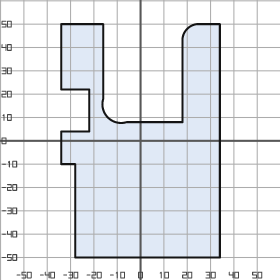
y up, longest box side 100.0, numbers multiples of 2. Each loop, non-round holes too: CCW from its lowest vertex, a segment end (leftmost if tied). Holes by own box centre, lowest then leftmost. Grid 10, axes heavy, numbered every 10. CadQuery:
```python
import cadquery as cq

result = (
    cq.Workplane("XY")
    .moveTo(-28.0, -50.0)
    .lineTo(34.0, -50.0)
    .lineTo(34.0, 50.0)
    .lineTo(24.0, 50.0)
    .threePointArc((20.0, 48.0), (18.0, 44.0))
    .lineTo(18.0, 8.0)
    .lineTo(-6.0, 8.0)
    .threePointArc((-14.0, 10.0), (-16.0, 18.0))
    .lineTo(-16.0, 50.0)
    .lineTo(-34.0, 50.0)
    .lineTo(-34.0, 22.0)
    .lineTo(-22.0, 22.0)
    .lineTo(-22.0, 4.0)
    .lineTo(-34.0, 4.0)
    .lineTo(-34.0, -10.0)
    .lineTo(-28.0, -10.0)
    .close()
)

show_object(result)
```